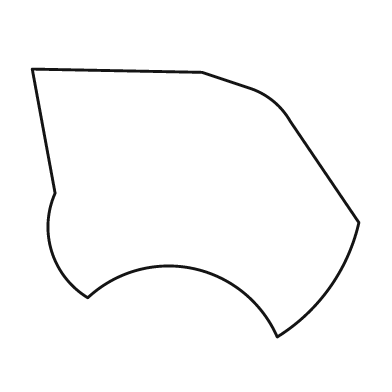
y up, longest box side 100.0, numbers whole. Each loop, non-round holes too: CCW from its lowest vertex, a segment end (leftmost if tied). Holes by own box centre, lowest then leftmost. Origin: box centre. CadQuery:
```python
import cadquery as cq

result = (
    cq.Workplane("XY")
    .moveTo(25.0, -41.0)
    .threePointArc((41.0, -26.0), (50.0, -6.0))
    .lineTo(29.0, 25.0)
    .threePointArc((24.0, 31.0), (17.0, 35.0))
    .lineTo(2.0, 40.0)
    .lineTo(-50.0, 41.0)
    .lineTo(-43.0, 3.0)
    .threePointArc((-44.0, -15.0), (-33.0, -29.0))
    .threePointArc((-1.0, -20.0), (25.0, -41.0))
    .close()
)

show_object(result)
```